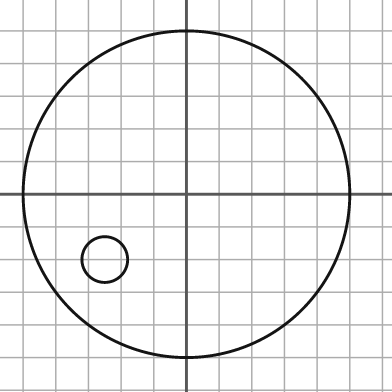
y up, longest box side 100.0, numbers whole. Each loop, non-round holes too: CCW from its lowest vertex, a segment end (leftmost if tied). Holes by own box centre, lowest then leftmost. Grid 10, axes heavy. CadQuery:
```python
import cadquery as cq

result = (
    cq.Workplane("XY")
    .moveTo(0.0, 0.0)
    .circle(50.0)
    .moveTo(-25.0, -20.0)
    .circle(7.0)
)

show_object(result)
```